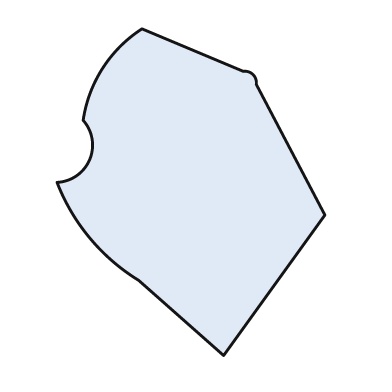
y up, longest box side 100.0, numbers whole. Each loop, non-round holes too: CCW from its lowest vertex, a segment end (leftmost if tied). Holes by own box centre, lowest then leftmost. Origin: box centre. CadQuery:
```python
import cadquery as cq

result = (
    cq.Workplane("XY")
    .moveTo(10.0, -50.0)
    .lineTo(41.0, -7.0)
    .lineTo(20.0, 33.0)
    .threePointArc((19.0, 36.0), (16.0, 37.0))
    .lineTo(-15.0, 50.0)
    .threePointArc((-27.0, 38.0), (-33.0, 22.0))
    .threePointArc((-31.0, 10.0), (-41.0, 3.0))
    .threePointArc((-31.0, -14.0), (-16.0, -27.0))
    .close()
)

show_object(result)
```